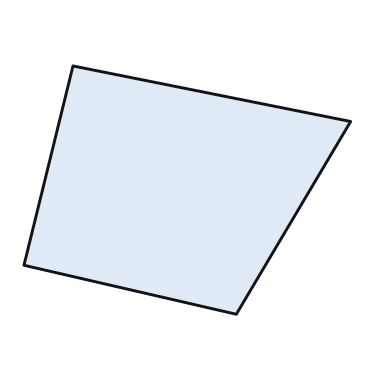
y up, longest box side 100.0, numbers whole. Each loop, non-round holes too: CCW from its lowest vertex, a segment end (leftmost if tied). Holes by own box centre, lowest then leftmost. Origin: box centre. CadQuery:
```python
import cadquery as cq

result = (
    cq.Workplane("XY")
    .moveTo(15.0, -38.0)
    .lineTo(50.0, 21.0)
    .lineTo(-35.0, 38.0)
    .lineTo(-50.0, -23.0)
    .close()
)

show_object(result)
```